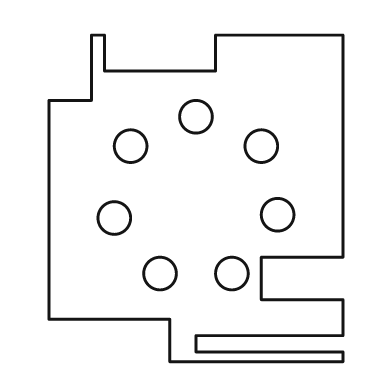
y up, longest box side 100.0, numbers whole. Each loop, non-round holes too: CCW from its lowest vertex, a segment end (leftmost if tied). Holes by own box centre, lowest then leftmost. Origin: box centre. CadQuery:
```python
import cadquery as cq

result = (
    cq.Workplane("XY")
    .moveTo(-8.0, -50.0)
    .lineTo(45.0, -50.0)
    .lineTo(45.0, -47.0)
    .lineTo(0.0, -47.0)
    .lineTo(0.0, -42.0)
    .lineTo(45.0, -42.0)
    .lineTo(45.0, -31.0)
    .lineTo(20.0, -31.0)
    .lineTo(20.0, -18.0)
    .lineTo(45.0, -18.0)
    .lineTo(45.0, 50.0)
    .lineTo(6.0, 50.0)
    .lineTo(6.0, 39.0)
    .lineTo(-28.0, 39.0)
    .lineTo(-28.0, 50.0)
    .lineTo(-32.0, 50.0)
    .lineTo(-32.0, 30.0)
    .lineTo(-45.0, 30.0)
    .lineTo(-45.0, -37.0)
    .lineTo(-8.0, -37.0)
    .close()
    .moveTo(-11.0, -23.0)
    .circle(5.0)
    .moveTo(11.0, -23.0)
    .circle(5.0)
    .moveTo(-25.0, -6.0)
    .circle(5.0)
    .moveTo(25.0, -5.0)
    .circle(5.0)
    .moveTo(-20.0, 16.0)
    .circle(5.0)
    .moveTo(20.0, 16.0)
    .circle(5.0)
    .moveTo(0.0, 25.0)
    .circle(5.0)
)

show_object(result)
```